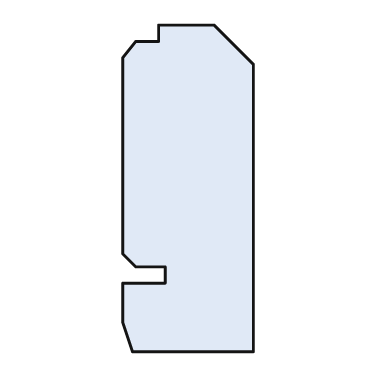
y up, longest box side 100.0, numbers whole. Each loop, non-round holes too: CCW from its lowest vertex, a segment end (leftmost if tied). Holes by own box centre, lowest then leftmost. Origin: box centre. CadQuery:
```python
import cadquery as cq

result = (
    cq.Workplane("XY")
    .moveTo(-17.0, -50.0)
    .lineTo(20.0, -50.0)
    .lineTo(20.0, 38.0)
    .lineTo(8.0, 50.0)
    .lineTo(-9.0, 50.0)
    .lineTo(-9.0, 45.0)
    .lineTo(-16.0, 45.0)
    .lineTo(-20.0, 40.0)
    .lineTo(-20.0, -20.0)
    .lineTo(-16.0, -24.0)
    .lineTo(-7.0, -24.0)
    .lineTo(-7.0, -29.0)
    .lineTo(-20.0, -29.0)
    .lineTo(-20.0, -41.0)
    .close()
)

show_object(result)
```